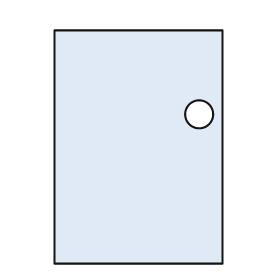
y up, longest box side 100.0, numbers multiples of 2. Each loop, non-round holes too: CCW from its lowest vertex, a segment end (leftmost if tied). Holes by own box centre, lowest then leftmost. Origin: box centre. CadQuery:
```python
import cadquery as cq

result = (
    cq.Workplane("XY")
    .moveTo(-36.0, -50.0)
    .lineTo(36.0, -50.0)
    .lineTo(36.0, 50.0)
    .lineTo(-36.0, 50.0)
    .close()
    .moveTo(26.0, 14.0)
    .circle(6.0)
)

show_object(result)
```